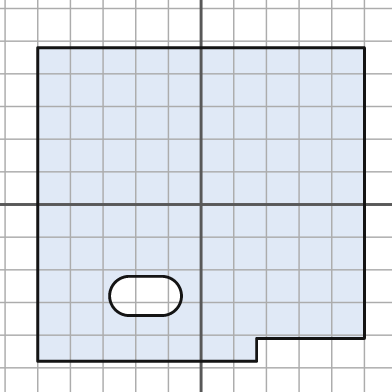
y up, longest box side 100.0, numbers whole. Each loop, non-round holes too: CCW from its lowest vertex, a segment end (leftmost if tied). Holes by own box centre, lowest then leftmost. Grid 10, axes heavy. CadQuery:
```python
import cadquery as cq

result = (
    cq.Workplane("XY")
    .moveTo(-50.0, -48.0)
    .lineTo(17.0, -48.0)
    .lineTo(17.0, -41.0)
    .lineTo(50.0, -41.0)
    .lineTo(50.0, 48.0)
    .lineTo(-50.0, 48.0)
    .close()
    .moveTo(-22.0, -34.0)
    .lineTo(-12.0, -34.0)
    .threePointArc((-6.0, -28.0), (-12.0, -22.0))
    .lineTo(-22.0, -22.0)
    .threePointArc((-28.0, -28.0), (-22.0, -34.0))
    .close()
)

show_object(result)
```